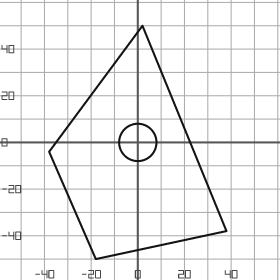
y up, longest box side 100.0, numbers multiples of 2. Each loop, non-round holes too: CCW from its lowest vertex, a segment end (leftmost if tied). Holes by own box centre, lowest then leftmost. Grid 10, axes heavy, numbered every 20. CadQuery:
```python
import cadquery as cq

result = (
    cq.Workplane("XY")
    .moveTo(-18.0, -50.0)
    .lineTo(38.0, -38.0)
    .lineTo(2.0, 50.0)
    .lineTo(-38.0, -4.0)
    .close()
    .moveTo(0.0, 0.0)
    .circle(8.0)
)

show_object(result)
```